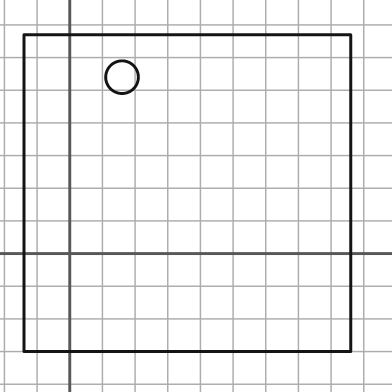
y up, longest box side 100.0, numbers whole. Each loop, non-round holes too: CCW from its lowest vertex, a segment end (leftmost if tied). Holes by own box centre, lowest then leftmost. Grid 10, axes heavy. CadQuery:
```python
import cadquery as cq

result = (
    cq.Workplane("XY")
    .moveTo(-14.0, -30.0)
    .lineTo(86.0, -30.0)
    .lineTo(86.0, 67.0)
    .lineTo(-14.0, 67.0)
    .close()
    .moveTo(16.0, 54.0)
    .circle(5.0)
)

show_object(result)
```